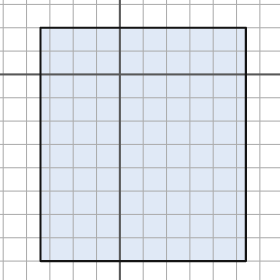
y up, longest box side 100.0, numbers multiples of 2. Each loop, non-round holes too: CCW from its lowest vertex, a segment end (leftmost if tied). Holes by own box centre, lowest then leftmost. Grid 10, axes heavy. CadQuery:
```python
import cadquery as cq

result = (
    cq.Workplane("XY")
    .moveTo(-34.0, -80.0)
    .lineTo(54.0, -80.0)
    .lineTo(54.0, 20.0)
    .lineTo(-34.0, 20.0)
    .close()
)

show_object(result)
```